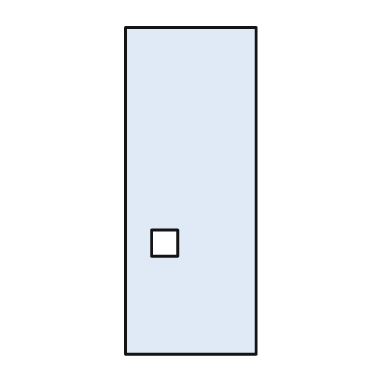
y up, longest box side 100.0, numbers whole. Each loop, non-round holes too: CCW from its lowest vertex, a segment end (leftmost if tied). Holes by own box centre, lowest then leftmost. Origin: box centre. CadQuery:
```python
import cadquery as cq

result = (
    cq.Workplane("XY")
    .moveTo(-20.0, -50.0)
    .lineTo(20.0, -50.0)
    .lineTo(20.0, 50.0)
    .lineTo(-20.0, 50.0)
    .close()
    .moveTo(-12.0, -20.0)
    .lineTo(-4.0, -20.0)
    .lineTo(-4.0, -12.0)
    .lineTo(-12.0, -12.0)
    .close()
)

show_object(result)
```